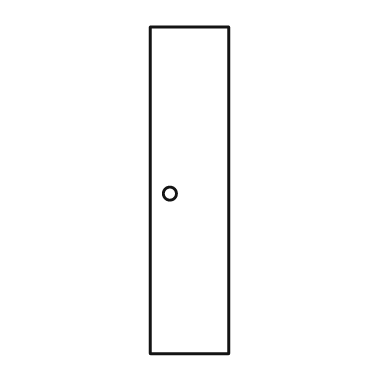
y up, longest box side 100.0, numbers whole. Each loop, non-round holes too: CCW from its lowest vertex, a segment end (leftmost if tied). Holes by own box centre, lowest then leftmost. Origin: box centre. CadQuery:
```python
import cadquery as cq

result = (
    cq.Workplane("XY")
    .moveTo(-12.0, -50.0)
    .lineTo(12.0, -50.0)
    .lineTo(12.0, 50.0)
    .lineTo(-12.0, 50.0)
    .close()
    .moveTo(-6.0, -1.0)
    .circle(2.0)
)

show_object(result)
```